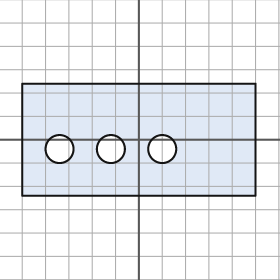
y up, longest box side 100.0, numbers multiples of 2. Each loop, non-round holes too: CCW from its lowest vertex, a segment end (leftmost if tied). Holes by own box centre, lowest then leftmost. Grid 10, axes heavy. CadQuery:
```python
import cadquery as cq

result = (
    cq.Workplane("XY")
    .moveTo(-50.0, -24.0)
    .lineTo(50.0, -24.0)
    .lineTo(50.0, 24.0)
    .lineTo(-50.0, 24.0)
    .close()
    .moveTo(-34.0, -4.0)
    .circle(6.0)
    .moveTo(-12.0, -4.0)
    .circle(6.0)
    .moveTo(10.0, -4.0)
    .circle(6.0)
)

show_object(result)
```